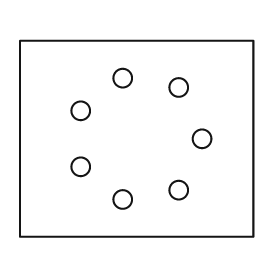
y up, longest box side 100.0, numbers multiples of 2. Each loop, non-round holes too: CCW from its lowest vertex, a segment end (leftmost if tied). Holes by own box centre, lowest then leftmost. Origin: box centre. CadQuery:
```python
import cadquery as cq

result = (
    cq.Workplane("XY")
    .moveTo(-50.0, -42.0)
    .lineTo(50.0, -42.0)
    .lineTo(50.0, 42.0)
    .lineTo(-50.0, 42.0)
    .close()
    .moveTo(-6.0, -26.0)
    .circle(4.0)
    .moveTo(18.0, -22.0)
    .circle(4.0)
    .moveTo(-24.0, -12.0)
    .circle(4.0)
    .moveTo(28.0, 0.0)
    .circle(4.0)
    .moveTo(-24.0, 12.0)
    .circle(4.0)
    .moveTo(18.0, 22.0)
    .circle(4.0)
    .moveTo(-6.0, 26.0)
    .circle(4.0)
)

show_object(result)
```